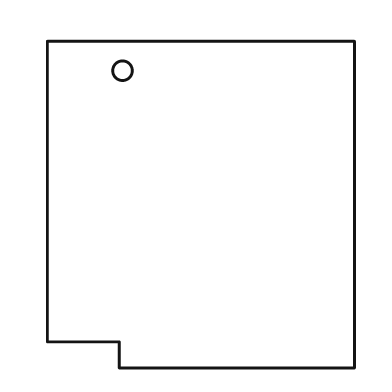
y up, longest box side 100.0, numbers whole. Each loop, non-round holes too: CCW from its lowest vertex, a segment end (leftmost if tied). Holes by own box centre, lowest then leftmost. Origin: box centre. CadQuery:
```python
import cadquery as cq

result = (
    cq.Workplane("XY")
    .moveTo(-25.0, -50.0)
    .lineTo(47.0, -50.0)
    .lineTo(47.0, 50.0)
    .lineTo(-47.0, 50.0)
    .lineTo(-47.0, -42.0)
    .lineTo(-25.0, -42.0)
    .close()
    .moveTo(-24.0, 41.0)
    .circle(3.0)
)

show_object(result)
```